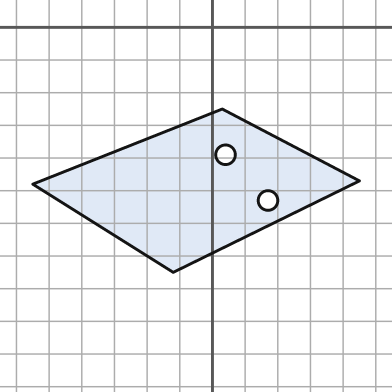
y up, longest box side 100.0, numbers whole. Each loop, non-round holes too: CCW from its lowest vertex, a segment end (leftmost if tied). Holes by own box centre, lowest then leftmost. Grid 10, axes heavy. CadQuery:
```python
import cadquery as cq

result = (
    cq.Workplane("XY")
    .moveTo(-12.0, -75.0)
    .lineTo(45.0, -47.0)
    .lineTo(3.0, -25.0)
    .lineTo(-55.0, -48.0)
    .close()
    .moveTo(17.0, -53.0)
    .circle(3.0)
    .moveTo(4.0, -39.0)
    .circle(3.0)
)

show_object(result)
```